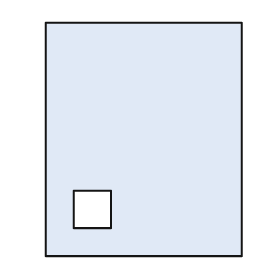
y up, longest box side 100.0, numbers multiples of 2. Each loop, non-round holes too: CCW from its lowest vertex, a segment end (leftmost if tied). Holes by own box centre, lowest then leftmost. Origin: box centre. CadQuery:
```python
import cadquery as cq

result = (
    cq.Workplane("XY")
    .moveTo(-42.0, -50.0)
    .lineTo(42.0, -50.0)
    .lineTo(42.0, 50.0)
    .lineTo(-42.0, 50.0)
    .close()
    .moveTo(-30.0, -38.0)
    .lineTo(-14.0, -38.0)
    .lineTo(-14.0, -22.0)
    .lineTo(-30.0, -22.0)
    .close()
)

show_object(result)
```